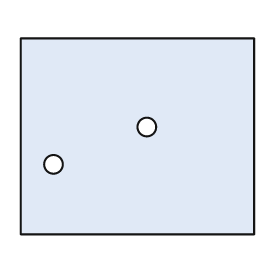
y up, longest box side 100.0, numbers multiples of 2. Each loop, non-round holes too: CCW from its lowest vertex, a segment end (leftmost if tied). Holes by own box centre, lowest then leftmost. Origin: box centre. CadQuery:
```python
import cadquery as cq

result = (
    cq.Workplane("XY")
    .moveTo(-50.0, -42.0)
    .lineTo(50.0, -42.0)
    .lineTo(50.0, 42.0)
    .lineTo(-50.0, 42.0)
    .close()
    .moveTo(-36.0, -12.0)
    .circle(4.0)
    .moveTo(4.0, 4.0)
    .circle(4.0)
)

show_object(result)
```